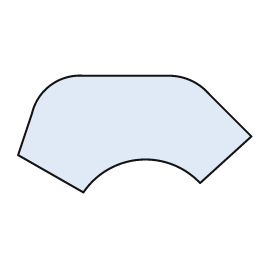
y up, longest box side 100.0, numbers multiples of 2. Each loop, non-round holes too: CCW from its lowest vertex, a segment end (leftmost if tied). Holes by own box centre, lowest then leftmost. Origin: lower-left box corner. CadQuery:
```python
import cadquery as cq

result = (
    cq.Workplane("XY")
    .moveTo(28.0, 0.0)
    .threePointArc((52.0, 14.0), (78.0, 4.0))
    .lineTo(100.0, 24.0)
    .lineTo(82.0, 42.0)
    .threePointArc((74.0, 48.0), (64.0, 50.0))
    .lineTo(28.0, 50.0)
    .threePointArc((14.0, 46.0), (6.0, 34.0))
    .lineTo(0.0, 16.0)
    .close()
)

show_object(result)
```